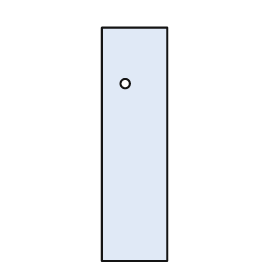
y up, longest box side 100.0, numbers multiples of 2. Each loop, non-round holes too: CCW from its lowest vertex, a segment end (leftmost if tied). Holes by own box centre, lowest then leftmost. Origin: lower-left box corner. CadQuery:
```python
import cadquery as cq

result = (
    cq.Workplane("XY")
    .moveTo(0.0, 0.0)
    .lineTo(28.0, 0.0)
    .lineTo(28.0, 100.0)
    .lineTo(0.0, 100.0)
    .close()
    .moveTo(10.0, 76.0)
    .circle(2.0)
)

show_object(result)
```